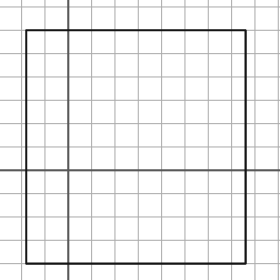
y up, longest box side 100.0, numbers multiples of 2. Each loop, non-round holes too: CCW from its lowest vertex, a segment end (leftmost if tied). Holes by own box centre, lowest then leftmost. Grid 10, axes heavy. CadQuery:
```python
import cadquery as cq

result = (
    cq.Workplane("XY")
    .moveTo(-18.0, -40.0)
    .lineTo(76.0, -40.0)
    .lineTo(76.0, 60.0)
    .lineTo(-18.0, 60.0)
    .close()
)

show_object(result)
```